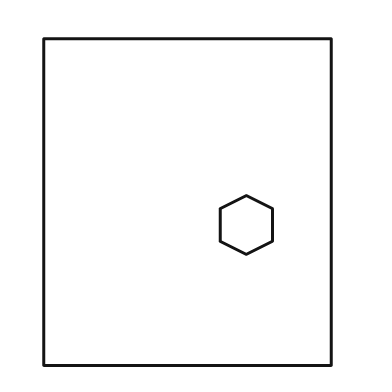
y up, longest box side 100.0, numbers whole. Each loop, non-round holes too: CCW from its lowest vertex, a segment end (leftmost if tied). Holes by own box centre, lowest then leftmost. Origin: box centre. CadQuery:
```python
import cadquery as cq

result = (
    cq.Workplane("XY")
    .moveTo(-44.0, -50.0)
    .lineTo(44.0, -50.0)
    .lineTo(44.0, 50.0)
    .lineTo(-44.0, 50.0)
    .close()
    .moveTo(18.0, -16.0)
    .lineTo(26.0, -12.0)
    .lineTo(26.0, -2.0)
    .lineTo(18.0, 2.0)
    .lineTo(10.0, -2.0)
    .lineTo(10.0, -12.0)
    .close()
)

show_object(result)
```